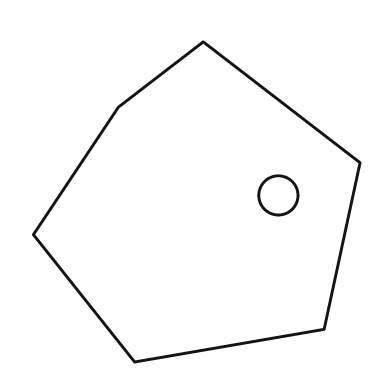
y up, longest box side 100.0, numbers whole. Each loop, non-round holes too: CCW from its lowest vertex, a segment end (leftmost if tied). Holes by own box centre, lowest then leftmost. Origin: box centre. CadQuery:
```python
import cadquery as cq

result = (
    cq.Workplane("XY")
    .moveTo(-19.0, -49.0)
    .lineTo(39.0, -39.0)
    .lineTo(50.0, 12.0)
    .lineTo(2.0, 49.0)
    .lineTo(-24.0, 29.0)
    .lineTo(-50.0, -10.0)
    .close()
    .moveTo(25.0, 2.0)
    .circle(6.0)
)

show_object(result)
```